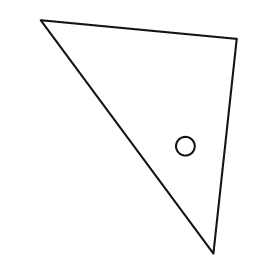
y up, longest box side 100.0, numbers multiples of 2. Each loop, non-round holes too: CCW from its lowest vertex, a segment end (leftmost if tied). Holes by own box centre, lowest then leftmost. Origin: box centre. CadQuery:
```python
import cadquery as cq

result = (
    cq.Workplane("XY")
    .moveTo(32.0, -50.0)
    .lineTo(42.0, 42.0)
    .lineTo(-42.0, 50.0)
    .close()
    .moveTo(20.0, -4.0)
    .circle(4.0)
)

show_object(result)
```